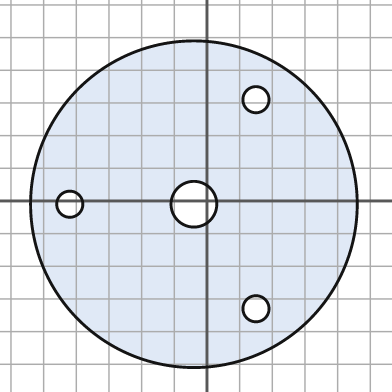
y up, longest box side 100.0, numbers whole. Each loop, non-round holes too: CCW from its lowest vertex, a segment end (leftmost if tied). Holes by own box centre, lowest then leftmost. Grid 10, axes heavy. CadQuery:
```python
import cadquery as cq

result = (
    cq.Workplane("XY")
    .moveTo(-4.0, -1.0)
    .circle(50.0)
    .moveTo(15.0, -33.0)
    .circle(4.0)
    .moveTo(-42.0, -1.0)
    .circle(4.0)
    .moveTo(-4.0, -1.0)
    .circle(7.0)
    .moveTo(15.0, 31.0)
    .circle(4.0)
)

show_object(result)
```